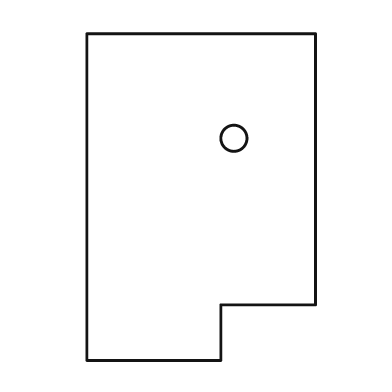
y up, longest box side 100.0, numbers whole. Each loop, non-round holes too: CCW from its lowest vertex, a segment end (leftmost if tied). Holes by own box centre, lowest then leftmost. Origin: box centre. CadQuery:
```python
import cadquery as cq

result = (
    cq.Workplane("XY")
    .moveTo(-35.0, -50.0)
    .lineTo(6.0, -50.0)
    .lineTo(6.0, -33.0)
    .lineTo(35.0, -33.0)
    .lineTo(35.0, 50.0)
    .lineTo(-35.0, 50.0)
    .close()
    .moveTo(10.0, 18.0)
    .circle(4.0)
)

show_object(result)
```